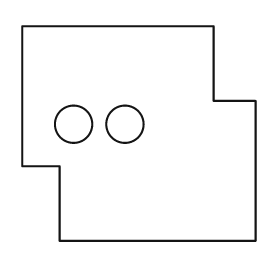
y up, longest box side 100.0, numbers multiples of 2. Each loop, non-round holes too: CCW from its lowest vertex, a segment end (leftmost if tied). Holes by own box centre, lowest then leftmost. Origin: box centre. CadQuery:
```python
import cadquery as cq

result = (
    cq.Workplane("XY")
    .moveTo(-34.0, -46.0)
    .lineTo(50.0, -46.0)
    .lineTo(50.0, 14.0)
    .lineTo(32.0, 14.0)
    .lineTo(32.0, 46.0)
    .lineTo(-50.0, 46.0)
    .lineTo(-50.0, -14.0)
    .lineTo(-34.0, -14.0)
    .close()
    .moveTo(-28.0, 4.0)
    .circle(8.0)
    .moveTo(-6.0, 4.0)
    .circle(8.0)
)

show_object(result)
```